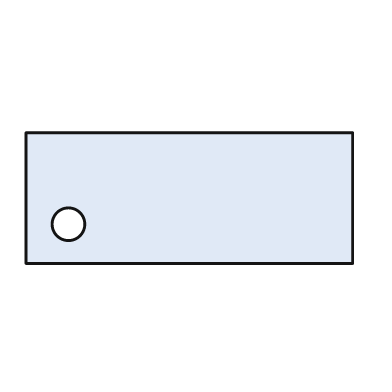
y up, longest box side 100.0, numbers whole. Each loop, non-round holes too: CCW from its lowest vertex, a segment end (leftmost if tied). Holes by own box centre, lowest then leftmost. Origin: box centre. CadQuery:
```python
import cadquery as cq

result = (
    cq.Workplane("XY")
    .moveTo(-50.0, -20.0)
    .lineTo(50.0, -20.0)
    .lineTo(50.0, 20.0)
    .lineTo(-50.0, 20.0)
    .close()
    .moveTo(-37.0, -8.0)
    .circle(5.0)
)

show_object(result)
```